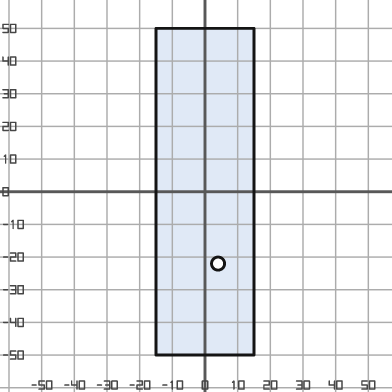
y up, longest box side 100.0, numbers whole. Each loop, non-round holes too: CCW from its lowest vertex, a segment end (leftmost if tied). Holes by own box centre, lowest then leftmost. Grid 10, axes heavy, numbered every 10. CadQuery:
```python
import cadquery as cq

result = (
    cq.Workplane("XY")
    .moveTo(-15.0, -50.0)
    .lineTo(15.0, -50.0)
    .lineTo(15.0, 50.0)
    .lineTo(-15.0, 50.0)
    .close()
    .moveTo(4.0, -22.0)
    .circle(2.0)
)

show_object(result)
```